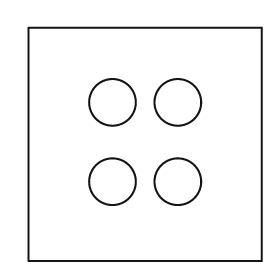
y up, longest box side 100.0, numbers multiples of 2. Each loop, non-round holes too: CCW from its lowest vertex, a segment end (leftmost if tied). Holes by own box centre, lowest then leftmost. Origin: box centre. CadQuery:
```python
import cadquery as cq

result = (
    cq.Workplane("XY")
    .moveTo(-50.0, -50.0)
    .lineTo(50.0, -50.0)
    .lineTo(50.0, 50.0)
    .lineTo(-50.0, 50.0)
    .close()
    .moveTo(-14.0, -16.0)
    .circle(10.0)
    .moveTo(14.0, -16.0)
    .circle(10.0)
    .moveTo(-14.0, 18.0)
    .circle(10.0)
    .moveTo(14.0, 18.0)
    .circle(10.0)
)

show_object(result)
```